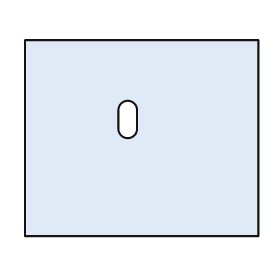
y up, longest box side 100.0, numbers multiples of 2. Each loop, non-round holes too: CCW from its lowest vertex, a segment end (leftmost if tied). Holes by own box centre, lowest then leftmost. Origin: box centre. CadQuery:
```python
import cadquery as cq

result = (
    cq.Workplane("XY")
    .moveTo(-50.0, -42.0)
    .lineTo(50.0, -42.0)
    .lineTo(50.0, 42.0)
    .lineTo(-50.0, 42.0)
    .close()
    .moveTo(-10.0, 4.0)
    .threePointArc((-6.0, 0.0), (-2.0, 4.0))
    .lineTo(-2.0, 12.0)
    .threePointArc((-6.0, 16.0), (-10.0, 12.0))
    .close()
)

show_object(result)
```